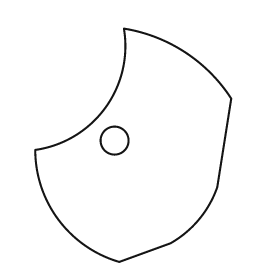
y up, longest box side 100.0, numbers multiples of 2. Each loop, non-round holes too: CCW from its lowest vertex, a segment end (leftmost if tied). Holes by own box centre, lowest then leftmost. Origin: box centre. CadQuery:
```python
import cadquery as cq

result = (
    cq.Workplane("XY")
    .moveTo(-6.0, -50.0)
    .lineTo(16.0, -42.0)
    .threePointArc((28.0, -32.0), (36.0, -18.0))
    .lineTo(42.0, 20.0)
    .threePointArc((22.0, 40.0), (-4.0, 50.0))
    .threePointArc((-12.0, 16.0), (-42.0, -2.0))
    .threePointArc((-32.0, -32.0), (-6.0, -50.0))
    .close()
    .moveTo(-8.0, 2.0)
    .circle(6.0)
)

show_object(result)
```